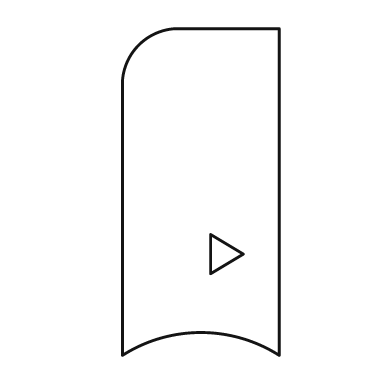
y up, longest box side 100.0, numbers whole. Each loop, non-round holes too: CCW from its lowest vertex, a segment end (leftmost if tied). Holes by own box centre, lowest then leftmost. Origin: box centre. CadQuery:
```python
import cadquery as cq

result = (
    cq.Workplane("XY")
    .moveTo(-24.0, -50.0)
    .threePointArc((0.0, -43.0), (24.0, -50.0))
    .lineTo(24.0, 50.0)
    .lineTo(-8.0, 50.0)
    .threePointArc((-19.0, 45.0), (-24.0, 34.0))
    .close()
    .moveTo(3.0, -25.0)
    .lineTo(13.0, -19.0)
    .lineTo(3.0, -13.0)
    .close()
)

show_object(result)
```